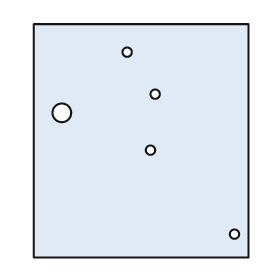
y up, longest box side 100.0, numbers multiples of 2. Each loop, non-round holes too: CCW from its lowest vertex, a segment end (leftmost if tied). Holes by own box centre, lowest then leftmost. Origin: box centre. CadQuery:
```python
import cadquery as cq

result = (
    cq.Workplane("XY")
    .moveTo(-46.0, -50.0)
    .lineTo(46.0, -50.0)
    .lineTo(46.0, 50.0)
    .lineTo(-46.0, 50.0)
    .close()
    .moveTo(40.0, -40.0)
    .circle(2.0)
    .moveTo(4.0, -4.0)
    .circle(2.0)
    .moveTo(-34.0, 12.0)
    .circle(4.0)
    .moveTo(6.0, 20.0)
    .circle(2.0)
    .moveTo(-6.0, 38.0)
    .circle(2.0)
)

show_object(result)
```